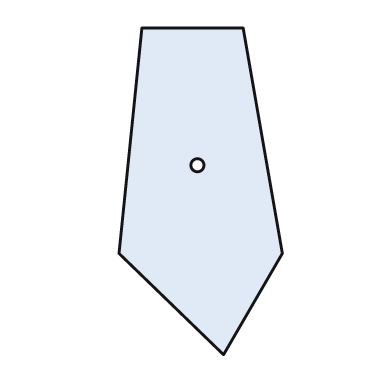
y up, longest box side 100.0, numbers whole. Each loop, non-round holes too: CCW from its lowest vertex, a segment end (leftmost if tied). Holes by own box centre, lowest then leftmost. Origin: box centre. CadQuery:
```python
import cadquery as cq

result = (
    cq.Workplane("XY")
    .moveTo(7.0, -50.0)
    .lineTo(25.0, -19.0)
    .lineTo(13.0, 50.0)
    .lineTo(-18.0, 50.0)
    .lineTo(-25.0, -19.0)
    .close()
    .moveTo(-1.0, 8.0)
    .circle(2.0)
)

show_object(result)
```